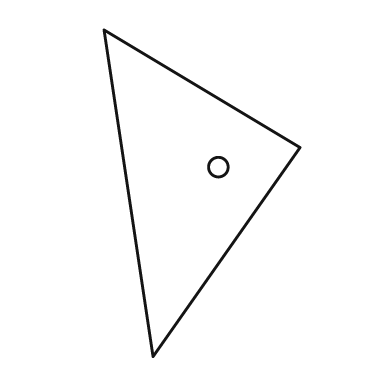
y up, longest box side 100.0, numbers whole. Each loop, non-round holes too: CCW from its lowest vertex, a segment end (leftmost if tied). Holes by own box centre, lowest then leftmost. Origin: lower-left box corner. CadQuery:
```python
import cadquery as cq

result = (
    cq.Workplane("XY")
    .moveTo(15.0, 0.0)
    .lineTo(60.0, 64.0)
    .lineTo(0.0, 100.0)
    .close()
    .moveTo(35.0, 58.0)
    .circle(3.0)
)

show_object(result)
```